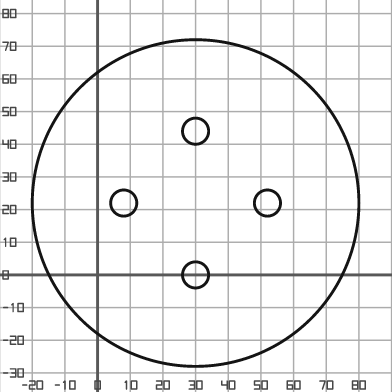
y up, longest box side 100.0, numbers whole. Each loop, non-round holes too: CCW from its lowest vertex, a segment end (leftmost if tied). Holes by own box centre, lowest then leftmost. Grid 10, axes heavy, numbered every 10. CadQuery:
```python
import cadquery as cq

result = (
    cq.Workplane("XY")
    .moveTo(30.0, 22.0)
    .circle(50.0)
    .moveTo(30.0, 0.0)
    .circle(4.0)
    .moveTo(8.0, 22.0)
    .circle(4.0)
    .moveTo(52.0, 22.0)
    .circle(4.0)
    .moveTo(30.0, 44.0)
    .circle(4.0)
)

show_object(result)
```